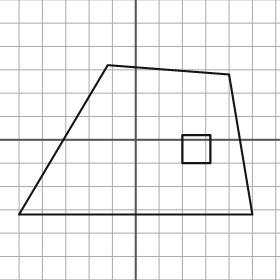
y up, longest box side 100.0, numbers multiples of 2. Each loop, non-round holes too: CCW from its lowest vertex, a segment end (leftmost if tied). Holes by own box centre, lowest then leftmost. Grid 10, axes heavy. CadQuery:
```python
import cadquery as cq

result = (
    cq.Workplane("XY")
    .moveTo(-50.0, -32.0)
    .lineTo(50.0, -32.0)
    .lineTo(40.0, 28.0)
    .lineTo(-12.0, 32.0)
    .close()
    .moveTo(20.0, -10.0)
    .lineTo(32.0, -10.0)
    .lineTo(32.0, 2.0)
    .lineTo(20.0, 2.0)
    .close()
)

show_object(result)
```